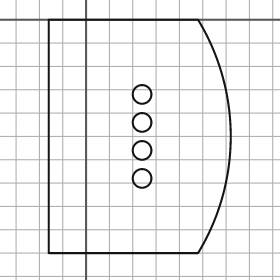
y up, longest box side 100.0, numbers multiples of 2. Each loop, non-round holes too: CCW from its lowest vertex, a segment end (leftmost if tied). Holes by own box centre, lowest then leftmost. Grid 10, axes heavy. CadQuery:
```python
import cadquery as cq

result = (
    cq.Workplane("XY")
    .moveTo(-16.0, -100.0)
    .lineTo(48.0, -100.0)
    .threePointArc((62.0, -50.0), (48.0, 0.0))
    .lineTo(-16.0, 0.0)
    .close()
    .moveTo(24.0, -68.0)
    .circle(4.0)
    .moveTo(24.0, -56.0)
    .circle(4.0)
    .moveTo(24.0, -44.0)
    .circle(4.0)
    .moveTo(24.0, -32.0)
    .circle(4.0)
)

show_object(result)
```